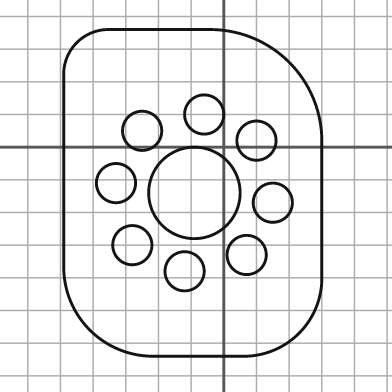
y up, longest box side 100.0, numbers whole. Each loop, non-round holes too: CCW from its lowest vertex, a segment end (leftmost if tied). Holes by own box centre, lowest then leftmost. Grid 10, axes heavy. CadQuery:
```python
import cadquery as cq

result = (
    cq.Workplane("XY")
    .moveTo(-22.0, -64.0)
    .lineTo(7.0, -64.0)
    .threePointArc((23.0, -57.0), (30.0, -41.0))
    .lineTo(30.0, 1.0)
    .threePointArc((20.0, 26.0), (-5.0, 36.0))
    .lineTo(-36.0, 36.0)
    .threePointArc((-45.0, 32.0), (-49.0, 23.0))
    .lineTo(-49.0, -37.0)
    .threePointArc((-41.0, -56.0), (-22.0, -64.0))
    .close()
    .moveTo(-12.0, -38.0)
    .circle(6.0)
    .moveTo(7.0, -33.0)
    .circle(6.0)
    .moveTo(-28.0, -30.0)
    .circle(6.0)
    .moveTo(15.0, -17.0)
    .circle(6.0)
    .moveTo(-9.0, -14.0)
    .circle(14.0)
    .moveTo(-33.0, -11.0)
    .circle(6.0)
    .moveTo(10.0, 2.0)
    .circle(6.0)
    .moveTo(-25.0, 5.0)
    .circle(6.0)
    .moveTo(-6.0, 10.0)
    .circle(6.0)
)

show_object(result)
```